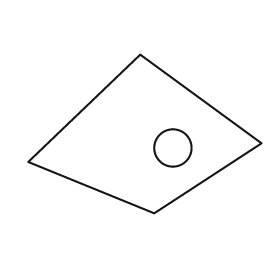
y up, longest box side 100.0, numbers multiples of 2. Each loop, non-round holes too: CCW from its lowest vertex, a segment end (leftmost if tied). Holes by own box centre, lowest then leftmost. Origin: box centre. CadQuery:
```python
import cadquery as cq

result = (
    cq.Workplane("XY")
    .moveTo(4.0, -34.0)
    .lineTo(50.0, -4.0)
    .lineTo(-2.0, 34.0)
    .lineTo(-50.0, -12.0)
    .close()
    .moveTo(12.0, -6.0)
    .circle(8.0)
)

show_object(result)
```